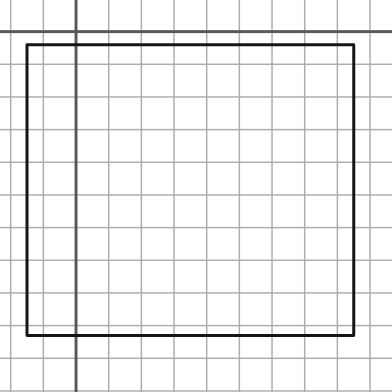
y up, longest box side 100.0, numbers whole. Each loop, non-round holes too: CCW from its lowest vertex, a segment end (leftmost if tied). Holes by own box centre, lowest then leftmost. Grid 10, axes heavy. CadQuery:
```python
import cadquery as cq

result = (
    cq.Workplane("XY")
    .moveTo(-15.0, -93.0)
    .lineTo(85.0, -93.0)
    .lineTo(85.0, -4.0)
    .lineTo(-15.0, -4.0)
    .close()
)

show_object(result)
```